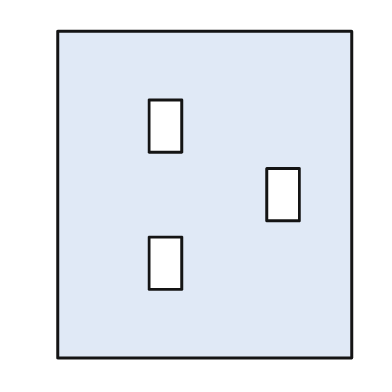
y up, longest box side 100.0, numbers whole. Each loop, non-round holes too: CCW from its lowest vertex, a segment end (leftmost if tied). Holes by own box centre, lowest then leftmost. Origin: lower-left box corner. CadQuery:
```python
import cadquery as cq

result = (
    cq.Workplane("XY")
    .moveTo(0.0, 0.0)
    .lineTo(90.0, 0.0)
    .lineTo(90.0, 100.0)
    .lineTo(0.0, 100.0)
    .close()
    .moveTo(28.0, 21.0)
    .lineTo(38.0, 21.0)
    .lineTo(38.0, 37.0)
    .lineTo(28.0, 37.0)
    .close()
    .moveTo(64.0, 42.0)
    .lineTo(74.0, 42.0)
    .lineTo(74.0, 58.0)
    .lineTo(64.0, 58.0)
    .close()
    .moveTo(28.0, 63.0)
    .lineTo(38.0, 63.0)
    .lineTo(38.0, 79.0)
    .lineTo(28.0, 79.0)
    .close()
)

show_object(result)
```